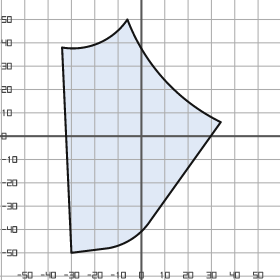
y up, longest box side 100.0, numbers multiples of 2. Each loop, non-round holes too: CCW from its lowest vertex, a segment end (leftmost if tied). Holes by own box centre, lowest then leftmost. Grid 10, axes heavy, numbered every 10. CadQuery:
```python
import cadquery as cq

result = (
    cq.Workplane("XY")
    .moveTo(-30.0, -50.0)
    .lineTo(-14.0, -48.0)
    .threePointArc((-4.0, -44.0), (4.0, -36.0))
    .lineTo(34.0, 6.0)
    .threePointArc((10.0, 24.0), (-6.0, 50.0))
    .threePointArc((-18.0, 40.0), (-34.0, 38.0))
    .close()
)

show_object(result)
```